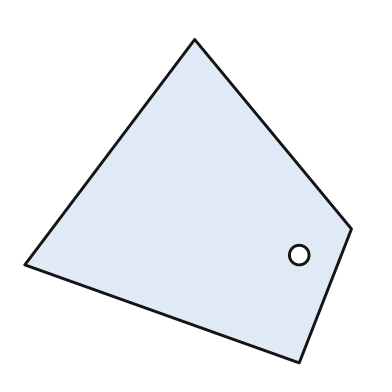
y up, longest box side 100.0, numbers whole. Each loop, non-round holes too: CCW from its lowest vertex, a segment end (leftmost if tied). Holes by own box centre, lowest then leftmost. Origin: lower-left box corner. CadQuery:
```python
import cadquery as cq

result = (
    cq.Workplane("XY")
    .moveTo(84.0, 0.0)
    .lineTo(100.0, 41.0)
    .lineTo(52.0, 99.0)
    .lineTo(0.0, 30.0)
    .close()
    .moveTo(84.0, 33.0)
    .circle(3.0)
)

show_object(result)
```